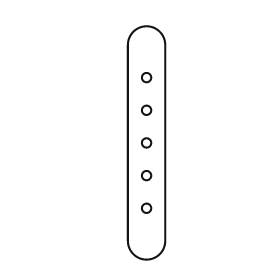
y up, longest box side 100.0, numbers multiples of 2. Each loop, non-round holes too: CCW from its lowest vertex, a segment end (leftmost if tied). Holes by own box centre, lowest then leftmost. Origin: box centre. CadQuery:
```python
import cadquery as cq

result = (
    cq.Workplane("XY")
    .moveTo(-8.0, -42.0)
    .threePointArc((0.0, -50.0), (8.0, -42.0))
    .lineTo(8.0, 42.0)
    .threePointArc((0.0, 50.0), (-8.0, 42.0))
    .close()
    .moveTo(0.0, -28.0)
    .circle(2.0)
    .moveTo(0.0, -14.0)
    .circle(2.0)
    .moveTo(0.0, 0.0)
    .circle(2.0)
    .moveTo(0.0, 14.0)
    .circle(2.0)
    .moveTo(0.0, 28.0)
    .circle(2.0)
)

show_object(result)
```